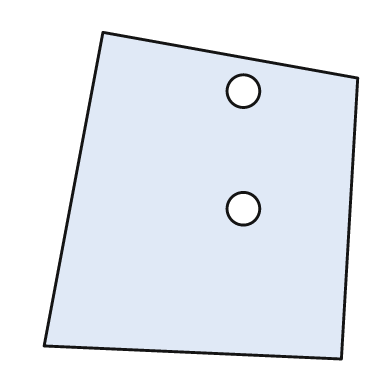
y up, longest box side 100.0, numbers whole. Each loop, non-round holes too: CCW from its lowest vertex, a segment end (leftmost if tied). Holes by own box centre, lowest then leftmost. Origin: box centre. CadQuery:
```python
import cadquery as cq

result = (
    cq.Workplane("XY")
    .moveTo(43.0, -50.0)
    .lineTo(48.0, 36.0)
    .lineTo(-30.0, 50.0)
    .lineTo(-48.0, -46.0)
    .close()
    .moveTo(13.0, -4.0)
    .circle(5.0)
    .moveTo(13.0, 32.0)
    .circle(5.0)
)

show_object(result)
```